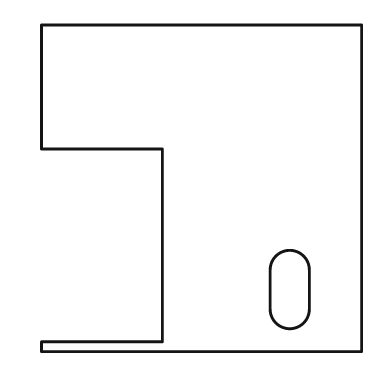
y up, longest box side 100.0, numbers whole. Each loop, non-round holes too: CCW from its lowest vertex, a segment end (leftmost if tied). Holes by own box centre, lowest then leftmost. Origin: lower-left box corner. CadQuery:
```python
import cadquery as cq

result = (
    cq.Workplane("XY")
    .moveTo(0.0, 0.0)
    .lineTo(98.0, 0.0)
    .lineTo(98.0, 100.0)
    .lineTo(0.0, 100.0)
    .lineTo(0.0, 62.0)
    .lineTo(37.0, 62.0)
    .lineTo(37.0, 3.0)
    .lineTo(0.0, 3.0)
    .close()
    .moveTo(70.0, 13.0)
    .threePointArc((76.0, 7.0), (82.0, 13.0))
    .lineTo(82.0, 25.0)
    .threePointArc((76.0, 31.0), (70.0, 25.0))
    .close()
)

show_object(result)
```